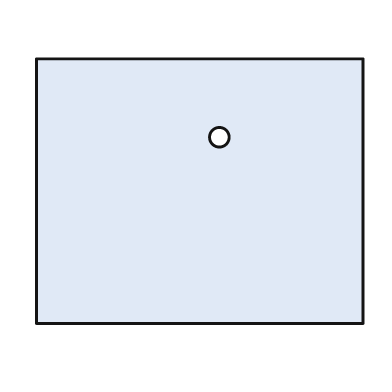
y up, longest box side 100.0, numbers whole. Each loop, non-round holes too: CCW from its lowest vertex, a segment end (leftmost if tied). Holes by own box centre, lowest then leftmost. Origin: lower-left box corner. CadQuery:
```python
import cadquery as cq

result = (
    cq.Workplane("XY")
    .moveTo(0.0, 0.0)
    .lineTo(100.0, 0.0)
    .lineTo(100.0, 81.0)
    .lineTo(0.0, 81.0)
    .close()
    .moveTo(56.0, 57.0)
    .circle(3.0)
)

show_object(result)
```